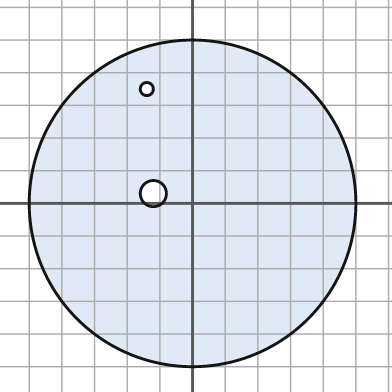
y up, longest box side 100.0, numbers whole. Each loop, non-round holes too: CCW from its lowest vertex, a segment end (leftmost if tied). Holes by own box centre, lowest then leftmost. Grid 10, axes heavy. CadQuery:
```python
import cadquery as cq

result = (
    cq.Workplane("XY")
    .moveTo(0.0, 0.0)
    .circle(50.0)
    .moveTo(-12.0, 3.0)
    .circle(4.0)
    .moveTo(-14.0, 35.0)
    .circle(2.0)
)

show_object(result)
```